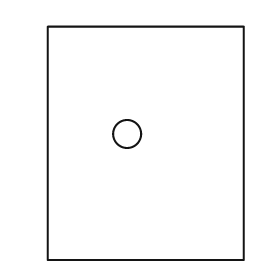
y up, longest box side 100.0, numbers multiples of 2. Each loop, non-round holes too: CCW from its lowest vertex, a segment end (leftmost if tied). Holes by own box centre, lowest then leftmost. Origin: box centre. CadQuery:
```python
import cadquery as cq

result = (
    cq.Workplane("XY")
    .moveTo(-42.0, -50.0)
    .lineTo(42.0, -50.0)
    .lineTo(42.0, 50.0)
    .lineTo(-42.0, 50.0)
    .close()
    .moveTo(-8.0, 4.0)
    .circle(6.0)
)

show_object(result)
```